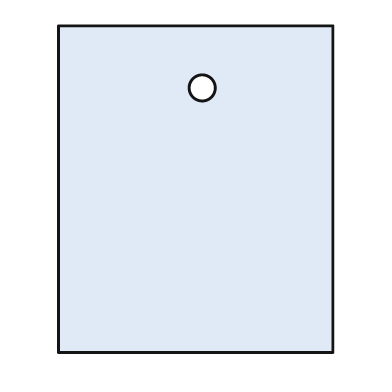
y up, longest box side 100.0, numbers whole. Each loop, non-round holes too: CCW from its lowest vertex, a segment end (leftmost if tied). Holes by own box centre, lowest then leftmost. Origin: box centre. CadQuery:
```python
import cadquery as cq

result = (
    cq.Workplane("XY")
    .moveTo(-42.0, -50.0)
    .lineTo(42.0, -50.0)
    .lineTo(42.0, 50.0)
    .lineTo(-42.0, 50.0)
    .close()
    .moveTo(2.0, 31.0)
    .circle(4.0)
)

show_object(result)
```